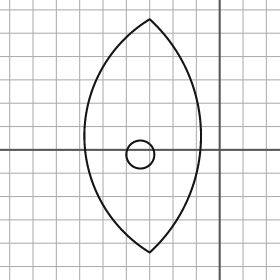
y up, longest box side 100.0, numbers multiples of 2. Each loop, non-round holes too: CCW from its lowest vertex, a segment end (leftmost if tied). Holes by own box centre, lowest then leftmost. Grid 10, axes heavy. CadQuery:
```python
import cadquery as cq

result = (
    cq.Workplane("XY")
    .moveTo(-30.0, -44.0)
    .threePointArc((-8.0, 6.0), (-30.0, 56.0))
    .threePointArc((-58.0, 6.0), (-30.0, -44.0))
    .close()
    .moveTo(-34.0, -2.0)
    .circle(6.0)
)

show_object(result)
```